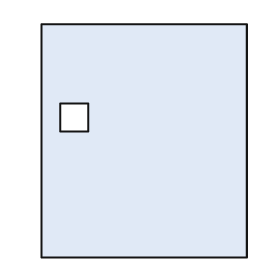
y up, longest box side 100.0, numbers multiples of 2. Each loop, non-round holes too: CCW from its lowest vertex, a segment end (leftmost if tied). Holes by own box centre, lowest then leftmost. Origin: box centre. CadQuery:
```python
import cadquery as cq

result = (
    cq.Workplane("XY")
    .moveTo(-44.0, -50.0)
    .lineTo(44.0, -50.0)
    .lineTo(44.0, 50.0)
    .lineTo(-44.0, 50.0)
    .close()
    .moveTo(-36.0, 4.0)
    .lineTo(-24.0, 4.0)
    .lineTo(-24.0, 16.0)
    .lineTo(-36.0, 16.0)
    .close()
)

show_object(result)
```